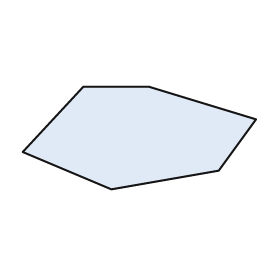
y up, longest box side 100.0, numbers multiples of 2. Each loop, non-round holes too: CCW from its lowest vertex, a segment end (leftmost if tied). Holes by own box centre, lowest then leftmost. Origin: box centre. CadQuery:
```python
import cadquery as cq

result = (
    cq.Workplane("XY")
    .moveTo(-12.0, -22.0)
    .lineTo(34.0, -14.0)
    .lineTo(50.0, 8.0)
    .lineTo(4.0, 22.0)
    .lineTo(-24.0, 22.0)
    .lineTo(-50.0, -6.0)
    .close()
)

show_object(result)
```